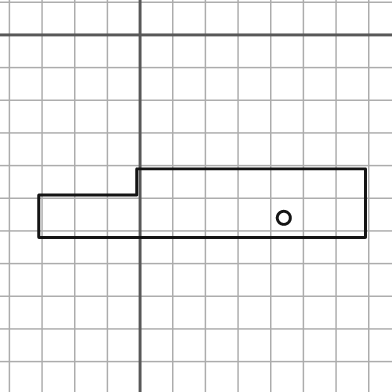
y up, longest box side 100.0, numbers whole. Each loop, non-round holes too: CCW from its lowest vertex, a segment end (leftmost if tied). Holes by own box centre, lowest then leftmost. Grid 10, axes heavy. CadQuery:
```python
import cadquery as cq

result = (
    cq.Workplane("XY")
    .moveTo(-31.0, -62.0)
    .lineTo(69.0, -62.0)
    .lineTo(69.0, -41.0)
    .lineTo(-1.0, -41.0)
    .lineTo(-1.0, -49.0)
    .lineTo(-31.0, -49.0)
    .close()
    .moveTo(44.0, -56.0)
    .circle(2.0)
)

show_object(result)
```